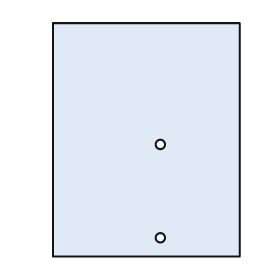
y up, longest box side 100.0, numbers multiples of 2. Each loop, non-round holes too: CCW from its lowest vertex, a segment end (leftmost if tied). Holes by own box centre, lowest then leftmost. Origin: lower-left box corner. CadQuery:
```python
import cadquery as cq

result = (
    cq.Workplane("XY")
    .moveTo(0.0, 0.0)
    .lineTo(80.0, 0.0)
    .lineTo(80.0, 100.0)
    .lineTo(0.0, 100.0)
    .close()
    .moveTo(46.0, 8.0)
    .circle(2.0)
    .moveTo(46.0, 48.0)
    .circle(2.0)
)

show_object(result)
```